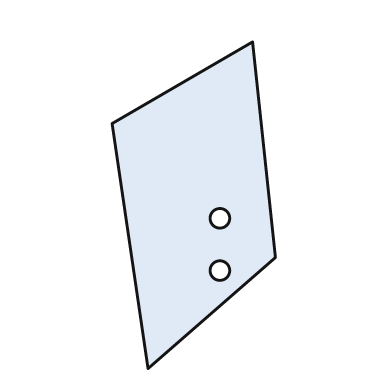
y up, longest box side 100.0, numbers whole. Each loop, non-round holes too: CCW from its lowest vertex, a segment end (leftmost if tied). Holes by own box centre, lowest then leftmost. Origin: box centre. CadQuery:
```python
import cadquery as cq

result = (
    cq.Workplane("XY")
    .moveTo(-14.0, -50.0)
    .lineTo(25.0, -16.0)
    .lineTo(18.0, 50.0)
    .lineTo(-25.0, 25.0)
    .close()
    .moveTo(8.0, -20.0)
    .circle(3.0)
    .moveTo(8.0, -4.0)
    .circle(3.0)
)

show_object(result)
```